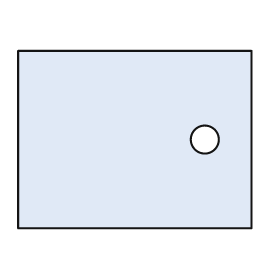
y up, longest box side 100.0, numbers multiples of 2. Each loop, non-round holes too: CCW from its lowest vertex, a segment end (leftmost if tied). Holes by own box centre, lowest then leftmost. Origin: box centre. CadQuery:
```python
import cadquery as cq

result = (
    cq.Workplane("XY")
    .moveTo(-50.0, -38.0)
    .lineTo(50.0, -38.0)
    .lineTo(50.0, 38.0)
    .lineTo(-50.0, 38.0)
    .close()
    .moveTo(30.0, 0.0)
    .circle(6.0)
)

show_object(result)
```